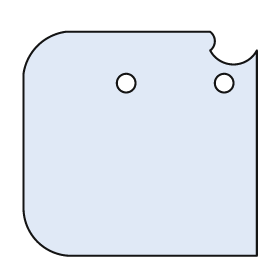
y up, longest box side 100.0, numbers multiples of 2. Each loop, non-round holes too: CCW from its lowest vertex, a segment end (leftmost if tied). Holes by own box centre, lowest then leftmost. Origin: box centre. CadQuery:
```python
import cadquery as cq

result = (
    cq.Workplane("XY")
    .moveTo(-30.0, -48.0)
    .lineTo(50.0, -48.0)
    .lineTo(50.0, 40.0)
    .threePointArc((40.0, 34.0), (30.0, 40.0))
    .threePointArc((32.0, 44.0), (30.0, 48.0))
    .lineTo(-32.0, 48.0)
    .threePointArc((-44.0, 42.0), (-50.0, 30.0))
    .lineTo(-50.0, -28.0)
    .threePointArc((-44.0, -42.0), (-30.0, -48.0))
    .close()
    .moveTo(-6.0, 26.0)
    .circle(4.0)
    .moveTo(36.0, 26.0)
    .circle(4.0)
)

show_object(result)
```